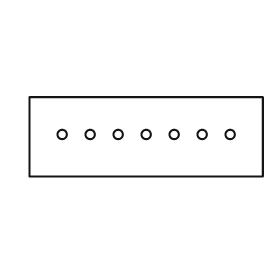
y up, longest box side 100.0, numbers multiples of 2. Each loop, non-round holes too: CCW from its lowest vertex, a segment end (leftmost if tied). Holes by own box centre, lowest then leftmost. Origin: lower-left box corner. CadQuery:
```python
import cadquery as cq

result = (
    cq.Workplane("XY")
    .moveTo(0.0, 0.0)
    .lineTo(100.0, 0.0)
    .lineTo(100.0, 34.0)
    .lineTo(0.0, 34.0)
    .close()
    .moveTo(14.0, 18.0)
    .circle(2.0)
    .moveTo(26.0, 18.0)
    .circle(2.0)
    .moveTo(38.0, 18.0)
    .circle(2.0)
    .moveTo(50.0, 18.0)
    .circle(2.0)
    .moveTo(62.0, 18.0)
    .circle(2.0)
    .moveTo(74.0, 18.0)
    .circle(2.0)
    .moveTo(86.0, 18.0)
    .circle(2.0)
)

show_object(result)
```